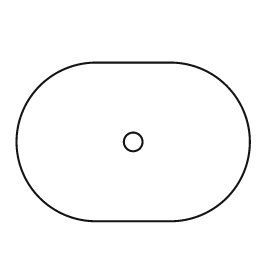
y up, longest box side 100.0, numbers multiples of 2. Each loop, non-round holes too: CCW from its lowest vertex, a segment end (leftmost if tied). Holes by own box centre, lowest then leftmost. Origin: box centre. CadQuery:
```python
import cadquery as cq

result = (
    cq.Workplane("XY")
    .moveTo(-16.0, -34.0)
    .lineTo(16.0, -34.0)
    .threePointArc((50.0, 0.0), (16.0, 34.0))
    .lineTo(-16.0, 34.0)
    .threePointArc((-50.0, 0.0), (-16.0, -34.0))
    .close()
    .moveTo(0.0, 0.0)
    .circle(4.0)
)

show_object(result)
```